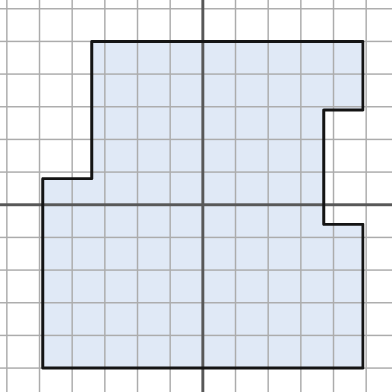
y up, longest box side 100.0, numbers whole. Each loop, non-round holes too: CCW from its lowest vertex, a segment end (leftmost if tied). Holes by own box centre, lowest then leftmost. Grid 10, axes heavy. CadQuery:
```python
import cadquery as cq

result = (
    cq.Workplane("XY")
    .moveTo(-49.0, -50.0)
    .lineTo(49.0, -50.0)
    .lineTo(49.0, -6.0)
    .lineTo(37.0, -6.0)
    .lineTo(37.0, 29.0)
    .lineTo(49.0, 29.0)
    .lineTo(49.0, 50.0)
    .lineTo(-34.0, 50.0)
    .lineTo(-34.0, 8.0)
    .lineTo(-49.0, 8.0)
    .close()
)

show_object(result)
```